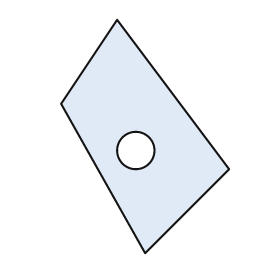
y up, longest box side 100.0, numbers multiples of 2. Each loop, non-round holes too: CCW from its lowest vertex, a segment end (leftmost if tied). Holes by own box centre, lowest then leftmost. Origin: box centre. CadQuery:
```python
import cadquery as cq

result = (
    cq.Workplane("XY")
    .moveTo(0.0, -50.0)
    .lineTo(36.0, -14.0)
    .lineTo(-12.0, 50.0)
    .lineTo(-36.0, 14.0)
    .close()
    .moveTo(-4.0, -6.0)
    .circle(8.0)
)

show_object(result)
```